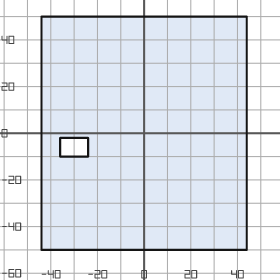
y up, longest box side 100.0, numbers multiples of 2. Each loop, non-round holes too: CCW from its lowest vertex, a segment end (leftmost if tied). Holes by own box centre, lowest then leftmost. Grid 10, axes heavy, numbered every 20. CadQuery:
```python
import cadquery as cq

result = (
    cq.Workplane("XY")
    .moveTo(-44.0, -50.0)
    .lineTo(44.0, -50.0)
    .lineTo(44.0, 50.0)
    .lineTo(-44.0, 50.0)
    .close()
    .moveTo(-36.0, -10.0)
    .lineTo(-24.0, -10.0)
    .lineTo(-24.0, -2.0)
    .lineTo(-36.0, -2.0)
    .close()
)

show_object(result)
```